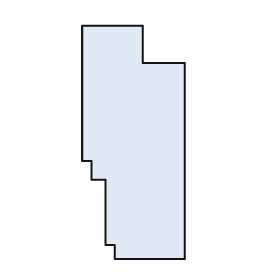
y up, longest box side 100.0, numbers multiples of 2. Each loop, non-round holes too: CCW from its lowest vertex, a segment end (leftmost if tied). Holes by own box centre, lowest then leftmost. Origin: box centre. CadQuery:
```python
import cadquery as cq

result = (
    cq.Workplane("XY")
    .moveTo(-8.0, -50.0)
    .lineTo(22.0, -50.0)
    .lineTo(22.0, 34.0)
    .lineTo(4.0, 34.0)
    .lineTo(4.0, 50.0)
    .lineTo(-22.0, 50.0)
    .lineTo(-22.0, -8.0)
    .lineTo(-18.0, -8.0)
    .lineTo(-18.0, -16.0)
    .lineTo(-12.0, -16.0)
    .lineTo(-12.0, -44.0)
    .lineTo(-8.0, -44.0)
    .close()
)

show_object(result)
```